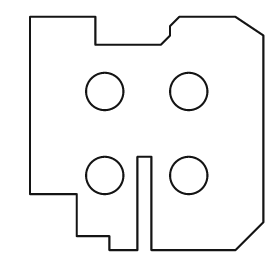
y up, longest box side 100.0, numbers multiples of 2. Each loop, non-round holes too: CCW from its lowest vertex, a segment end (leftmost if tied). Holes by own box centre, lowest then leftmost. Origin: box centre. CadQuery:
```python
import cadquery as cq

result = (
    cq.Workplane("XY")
    .moveTo(-16.0, -50.0)
    .lineTo(-4.0, -50.0)
    .lineTo(-4.0, -10.0)
    .lineTo(2.0, -10.0)
    .lineTo(2.0, -50.0)
    .lineTo(38.0, -50.0)
    .lineTo(50.0, -38.0)
    .lineTo(50.0, 42.0)
    .lineTo(38.0, 50.0)
    .lineTo(14.0, 50.0)
    .lineTo(10.0, 46.0)
    .lineTo(10.0, 42.0)
    .lineTo(6.0, 38.0)
    .lineTo(-22.0, 38.0)
    .lineTo(-22.0, 50.0)
    .lineTo(-50.0, 50.0)
    .lineTo(-50.0, -26.0)
    .lineTo(-30.0, -26.0)
    .lineTo(-30.0, -44.0)
    .lineTo(-16.0, -44.0)
    .close()
    .moveTo(-18.0, -18.0)
    .circle(8.0)
    .moveTo(18.0, -18.0)
    .circle(8.0)
    .moveTo(-18.0, 18.0)
    .circle(8.0)
    .moveTo(18.0, 18.0)
    .circle(8.0)
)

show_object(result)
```